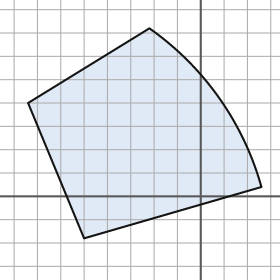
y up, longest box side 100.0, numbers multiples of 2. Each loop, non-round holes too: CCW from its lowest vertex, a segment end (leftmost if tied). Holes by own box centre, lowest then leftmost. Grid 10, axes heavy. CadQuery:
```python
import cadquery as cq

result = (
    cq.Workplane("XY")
    .moveTo(-50.0, -18.0)
    .lineTo(26.0, 4.0)
    .threePointArc((8.0, 42.0), (-22.0, 72.0))
    .lineTo(-74.0, 40.0)
    .close()
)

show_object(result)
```